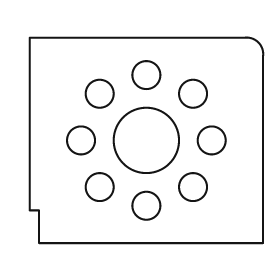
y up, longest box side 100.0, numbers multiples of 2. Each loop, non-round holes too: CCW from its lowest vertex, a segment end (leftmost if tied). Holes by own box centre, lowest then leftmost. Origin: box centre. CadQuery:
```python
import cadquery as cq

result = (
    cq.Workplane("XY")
    .moveTo(-46.0, -44.0)
    .lineTo(50.0, -44.0)
    .lineTo(50.0, 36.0)
    .threePointArc((48.0, 42.0), (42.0, 44.0))
    .lineTo(-50.0, 44.0)
    .lineTo(-50.0, -30.0)
    .lineTo(-46.0, -30.0)
    .close()
    .moveTo(0.0, -28.0)
    .circle(6.0)
    .moveTo(-20.0, -20.0)
    .circle(6.0)
    .moveTo(20.0, -20.0)
    .circle(6.0)
    .moveTo(-28.0, 0.0)
    .circle(6.0)
    .moveTo(0.0, 0.0)
    .circle(14.0)
    .moveTo(28.0, 0.0)
    .circle(6.0)
    .moveTo(-20.0, 20.0)
    .circle(6.0)
    .moveTo(20.0, 20.0)
    .circle(6.0)
    .moveTo(0.0, 28.0)
    .circle(6.0)
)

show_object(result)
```